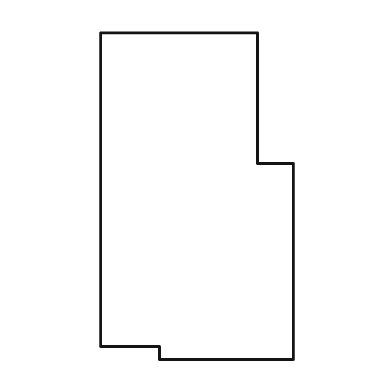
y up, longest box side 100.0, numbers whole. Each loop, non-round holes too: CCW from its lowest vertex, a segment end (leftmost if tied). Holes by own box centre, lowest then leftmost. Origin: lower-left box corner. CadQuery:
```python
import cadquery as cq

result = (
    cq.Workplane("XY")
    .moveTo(18.0, 0.0)
    .lineTo(59.0, 0.0)
    .lineTo(59.0, 60.0)
    .lineTo(48.0, 60.0)
    .lineTo(48.0, 100.0)
    .lineTo(0.0, 100.0)
    .lineTo(0.0, 4.0)
    .lineTo(18.0, 4.0)
    .close()
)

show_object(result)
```